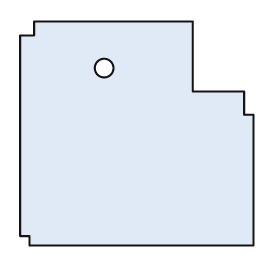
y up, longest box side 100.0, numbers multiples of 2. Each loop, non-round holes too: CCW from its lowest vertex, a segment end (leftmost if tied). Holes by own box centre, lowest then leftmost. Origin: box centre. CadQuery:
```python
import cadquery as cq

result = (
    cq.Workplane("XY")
    .moveTo(-46.0, -48.0)
    .lineTo(50.0, -48.0)
    .lineTo(50.0, 8.0)
    .lineTo(46.0, 8.0)
    .lineTo(46.0, 18.0)
    .lineTo(24.0, 18.0)
    .lineTo(24.0, 48.0)
    .lineTo(-44.0, 48.0)
    .lineTo(-44.0, 42.0)
    .lineTo(-50.0, 42.0)
    .lineTo(-50.0, -44.0)
    .lineTo(-46.0, -44.0)
    .close()
    .moveTo(-14.0, 28.0)
    .circle(4.0)
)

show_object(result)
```